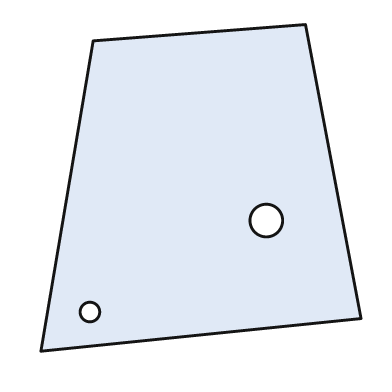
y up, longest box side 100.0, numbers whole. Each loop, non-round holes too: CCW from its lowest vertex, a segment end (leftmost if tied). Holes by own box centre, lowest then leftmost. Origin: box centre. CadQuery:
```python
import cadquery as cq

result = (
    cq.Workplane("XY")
    .moveTo(-49.0, -50.0)
    .lineTo(49.0, -40.0)
    .lineTo(32.0, 50.0)
    .lineTo(-33.0, 45.0)
    .close()
    .moveTo(-34.0, -38.0)
    .circle(3.0)
    .moveTo(20.0, -10.0)
    .circle(5.0)
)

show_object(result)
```